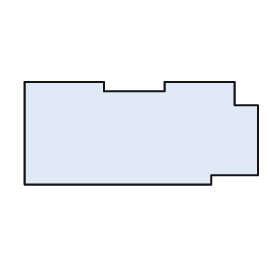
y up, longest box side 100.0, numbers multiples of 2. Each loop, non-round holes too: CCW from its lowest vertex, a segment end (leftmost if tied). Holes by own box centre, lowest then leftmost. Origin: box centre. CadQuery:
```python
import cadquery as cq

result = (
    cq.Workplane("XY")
    .moveTo(-50.0, -22.0)
    .lineTo(30.0, -22.0)
    .lineTo(30.0, -18.0)
    .lineTo(50.0, -18.0)
    .lineTo(50.0, 12.0)
    .lineTo(40.0, 12.0)
    .lineTo(40.0, 22.0)
    .lineTo(10.0, 22.0)
    .lineTo(10.0, 18.0)
    .lineTo(-16.0, 18.0)
    .lineTo(-16.0, 22.0)
    .lineTo(-50.0, 22.0)
    .close()
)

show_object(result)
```